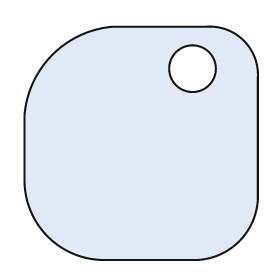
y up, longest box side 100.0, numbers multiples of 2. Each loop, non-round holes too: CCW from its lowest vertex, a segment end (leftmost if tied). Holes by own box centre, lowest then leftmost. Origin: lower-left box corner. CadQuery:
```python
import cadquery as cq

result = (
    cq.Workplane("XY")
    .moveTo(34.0, 0.0)
    .lineTo(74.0, 0.0)
    .threePointArc((92.0, 8.0), (100.0, 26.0))
    .lineTo(100.0, 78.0)
    .threePointArc((94.0, 94.0), (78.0, 100.0))
    .lineTo(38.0, 100.0)
    .threePointArc((12.0, 88.0), (0.0, 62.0))
    .lineTo(0.0, 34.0)
    .threePointArc((10.0, 10.0), (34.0, 0.0))
    .close()
    .moveTo(72.0, 82.0)
    .circle(10.0)
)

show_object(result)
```